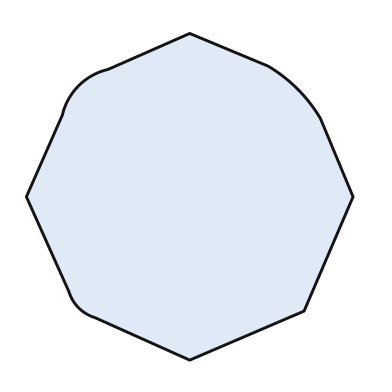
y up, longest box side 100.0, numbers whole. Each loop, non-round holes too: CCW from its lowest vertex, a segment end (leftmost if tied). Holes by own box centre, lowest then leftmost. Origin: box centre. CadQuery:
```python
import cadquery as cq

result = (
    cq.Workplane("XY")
    .moveTo(0.0, -50.0)
    .lineTo(35.0, -35.0)
    .lineTo(50.0, 0.0)
    .lineTo(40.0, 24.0)
    .threePointArc((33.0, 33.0), (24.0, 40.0))
    .lineTo(0.0, 50.0)
    .lineTo(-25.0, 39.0)
    .threePointArc((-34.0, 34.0), (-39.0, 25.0))
    .lineTo(-50.0, 0.0)
    .lineTo(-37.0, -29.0)
    .threePointArc((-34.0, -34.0), (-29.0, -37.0))
    .close()
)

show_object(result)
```